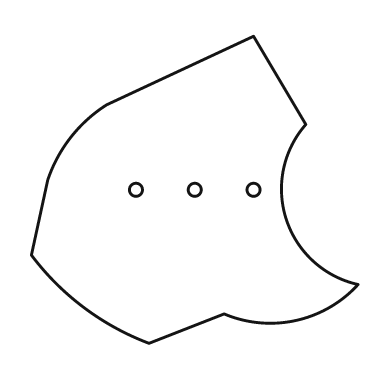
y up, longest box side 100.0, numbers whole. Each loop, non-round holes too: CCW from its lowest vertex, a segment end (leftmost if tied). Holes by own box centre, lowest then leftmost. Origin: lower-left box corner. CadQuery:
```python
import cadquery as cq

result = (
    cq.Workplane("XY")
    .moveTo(36.0, 0.0)
    .lineTo(59.0, 9.0)
    .threePointArc((81.0, 7.0), (100.0, 18.0))
    .threePointArc((78.0, 38.0), (84.0, 67.0))
    .lineTo(68.0, 94.0)
    .lineTo(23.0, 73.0)
    .threePointArc((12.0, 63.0), (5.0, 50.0))
    .lineTo(0.0, 27.0)
    .threePointArc((16.0, 11.0), (36.0, 0.0))
    .close()
    .moveTo(32.0, 47.0)
    .circle(2.0)
    .moveTo(50.0, 47.0)
    .circle(2.0)
    .moveTo(68.0, 47.0)
    .circle(2.0)
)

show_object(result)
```